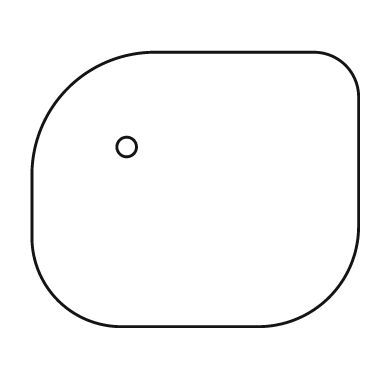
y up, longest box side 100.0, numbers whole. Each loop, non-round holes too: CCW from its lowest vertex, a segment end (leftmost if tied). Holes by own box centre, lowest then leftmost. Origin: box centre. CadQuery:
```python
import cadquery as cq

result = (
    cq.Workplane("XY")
    .moveTo(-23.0, -42.0)
    .lineTo(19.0, -42.0)
    .threePointArc((41.0, -33.0), (50.0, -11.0))
    .lineTo(50.0, 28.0)
    .threePointArc((46.0, 38.0), (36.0, 42.0))
    .lineTo(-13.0, 42.0)
    .threePointArc((-39.0, 31.0), (-50.0, 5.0))
    .lineTo(-50.0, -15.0)
    .threePointArc((-42.0, -34.0), (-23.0, -42.0))
    .close()
    .moveTo(-21.0, 13.0)
    .circle(3.0)
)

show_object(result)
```